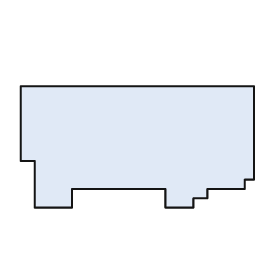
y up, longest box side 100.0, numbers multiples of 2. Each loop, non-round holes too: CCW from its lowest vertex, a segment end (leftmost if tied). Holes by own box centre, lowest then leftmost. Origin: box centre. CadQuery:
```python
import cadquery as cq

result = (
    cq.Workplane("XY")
    .moveTo(-44.0, -26.0)
    .lineTo(-28.0, -26.0)
    .lineTo(-28.0, -18.0)
    .lineTo(12.0, -18.0)
    .lineTo(12.0, -26.0)
    .lineTo(24.0, -26.0)
    .lineTo(24.0, -22.0)
    .lineTo(30.0, -22.0)
    .lineTo(30.0, -18.0)
    .lineTo(46.0, -18.0)
    .lineTo(46.0, -14.0)
    .lineTo(50.0, -14.0)
    .lineTo(50.0, 26.0)
    .lineTo(-50.0, 26.0)
    .lineTo(-50.0, -6.0)
    .lineTo(-44.0, -6.0)
    .close()
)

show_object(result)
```